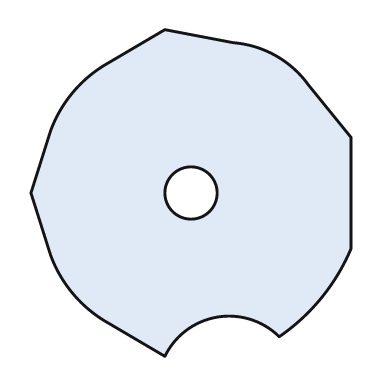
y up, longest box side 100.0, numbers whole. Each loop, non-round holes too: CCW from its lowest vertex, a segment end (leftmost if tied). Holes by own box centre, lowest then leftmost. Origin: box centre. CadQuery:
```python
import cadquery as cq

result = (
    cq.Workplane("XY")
    .moveTo(-8.0, -50.0)
    .threePointArc((8.0, -38.0), (27.0, -44.0))
    .threePointArc((40.0, -32.0), (49.0, -17.0))
    .lineTo(49.0, 17.0)
    .lineTo(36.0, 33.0)
    .threePointArc((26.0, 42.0), (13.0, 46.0))
    .lineTo(-8.0, 50.0)
    .lineTo(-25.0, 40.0)
    .threePointArc((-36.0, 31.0), (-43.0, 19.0))
    .lineTo(-49.0, 0.0)
    .lineTo(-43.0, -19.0)
    .threePointArc((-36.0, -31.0), (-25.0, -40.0))
    .close()
    .moveTo(0.0, 0.0)
    .circle(8.0)
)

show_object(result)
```